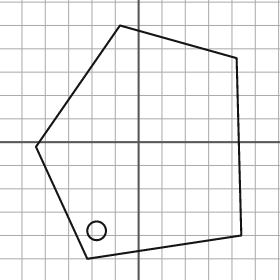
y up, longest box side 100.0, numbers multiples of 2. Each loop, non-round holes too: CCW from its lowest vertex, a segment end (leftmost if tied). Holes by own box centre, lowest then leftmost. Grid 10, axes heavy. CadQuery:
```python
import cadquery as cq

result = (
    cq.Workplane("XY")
    .moveTo(-22.0, -50.0)
    .lineTo(44.0, -40.0)
    .lineTo(42.0, 36.0)
    .lineTo(-8.0, 50.0)
    .lineTo(-44.0, -2.0)
    .close()
    .moveTo(-18.0, -38.0)
    .circle(4.0)
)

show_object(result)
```